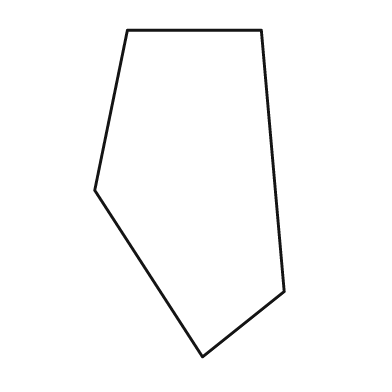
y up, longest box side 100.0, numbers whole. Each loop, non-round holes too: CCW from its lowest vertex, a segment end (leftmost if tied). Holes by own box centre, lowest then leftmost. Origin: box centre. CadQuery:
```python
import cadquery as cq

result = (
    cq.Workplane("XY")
    .moveTo(4.0, -50.0)
    .lineTo(29.0, -30.0)
    .lineTo(22.0, 50.0)
    .lineTo(-19.0, 50.0)
    .lineTo(-29.0, 1.0)
    .close()
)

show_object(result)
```